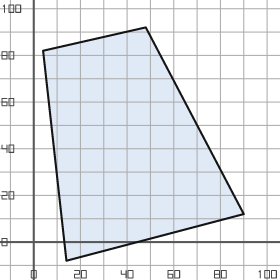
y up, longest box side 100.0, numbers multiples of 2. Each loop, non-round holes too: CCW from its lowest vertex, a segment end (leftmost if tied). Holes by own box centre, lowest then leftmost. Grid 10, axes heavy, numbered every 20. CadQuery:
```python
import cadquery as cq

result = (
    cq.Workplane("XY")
    .moveTo(14.0, -8.0)
    .lineTo(90.0, 12.0)
    .lineTo(48.0, 92.0)
    .lineTo(4.0, 82.0)
    .close()
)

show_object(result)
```